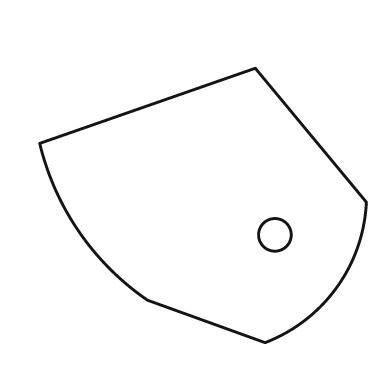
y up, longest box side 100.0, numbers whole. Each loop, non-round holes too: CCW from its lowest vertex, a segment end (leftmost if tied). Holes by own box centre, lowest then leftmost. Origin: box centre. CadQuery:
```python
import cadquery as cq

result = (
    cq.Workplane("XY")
    .moveTo(19.0, -42.0)
    .threePointArc((41.0, -25.0), (50.0, 1.0))
    .lineTo(16.0, 42.0)
    .lineTo(-50.0, 19.0)
    .threePointArc((-38.0, -8.0), (-17.0, -29.0))
    .close()
    .moveTo(22.0, -9.0)
    .circle(5.0)
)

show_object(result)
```